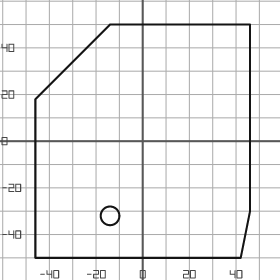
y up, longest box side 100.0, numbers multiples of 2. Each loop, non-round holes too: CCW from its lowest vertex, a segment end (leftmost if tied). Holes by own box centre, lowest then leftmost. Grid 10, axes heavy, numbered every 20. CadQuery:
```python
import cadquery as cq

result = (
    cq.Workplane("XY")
    .moveTo(-46.0, -50.0)
    .lineTo(42.0, -50.0)
    .lineTo(46.0, -30.0)
    .lineTo(46.0, 50.0)
    .lineTo(-14.0, 50.0)
    .lineTo(-46.0, 18.0)
    .close()
    .moveTo(-14.0, -32.0)
    .circle(4.0)
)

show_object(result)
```